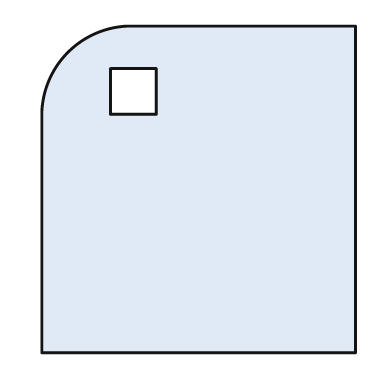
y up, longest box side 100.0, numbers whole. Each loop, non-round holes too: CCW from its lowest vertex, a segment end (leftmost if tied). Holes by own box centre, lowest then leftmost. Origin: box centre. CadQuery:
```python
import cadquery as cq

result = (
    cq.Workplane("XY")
    .moveTo(-48.0, -50.0)
    .lineTo(48.0, -50.0)
    .lineTo(48.0, 50.0)
    .lineTo(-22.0, 50.0)
    .threePointArc((-40.0, 42.0), (-48.0, 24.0))
    .close()
    .moveTo(-27.0, 23.0)
    .lineTo(-13.0, 23.0)
    .lineTo(-13.0, 37.0)
    .lineTo(-27.0, 37.0)
    .close()
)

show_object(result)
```